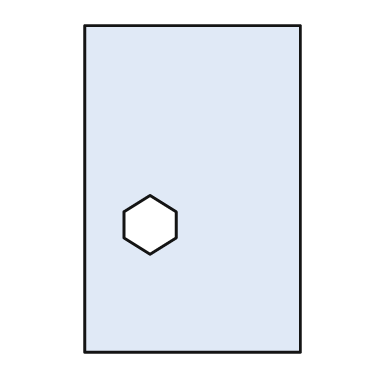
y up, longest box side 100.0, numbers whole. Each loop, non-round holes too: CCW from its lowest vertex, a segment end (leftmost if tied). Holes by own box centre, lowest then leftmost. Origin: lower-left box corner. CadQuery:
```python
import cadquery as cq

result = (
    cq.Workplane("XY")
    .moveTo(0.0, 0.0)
    .lineTo(66.0, 0.0)
    .lineTo(66.0, 100.0)
    .lineTo(0.0, 100.0)
    .close()
    .moveTo(20.0, 30.0)
    .lineTo(28.0, 35.0)
    .lineTo(28.0, 43.0)
    .lineTo(20.0, 48.0)
    .lineTo(12.0, 43.0)
    .lineTo(12.0, 35.0)
    .close()
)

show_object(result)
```